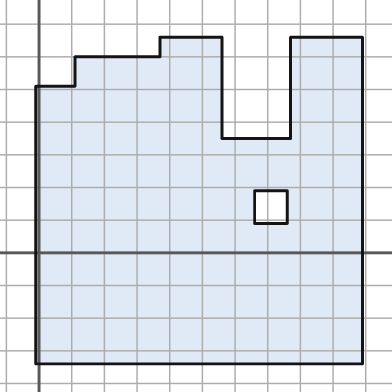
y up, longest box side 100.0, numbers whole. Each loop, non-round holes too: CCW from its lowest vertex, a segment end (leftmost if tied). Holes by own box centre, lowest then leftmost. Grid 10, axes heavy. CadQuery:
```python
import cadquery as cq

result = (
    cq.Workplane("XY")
    .moveTo(-1.0, -34.0)
    .lineTo(99.0, -34.0)
    .lineTo(99.0, 66.0)
    .lineTo(77.0, 66.0)
    .lineTo(77.0, 35.0)
    .lineTo(56.0, 35.0)
    .lineTo(56.0, 66.0)
    .lineTo(37.0, 66.0)
    .lineTo(37.0, 60.0)
    .lineTo(11.0, 60.0)
    .lineTo(11.0, 51.0)
    .lineTo(-1.0, 51.0)
    .close()
    .moveTo(66.0, 9.0)
    .lineTo(76.0, 9.0)
    .lineTo(76.0, 19.0)
    .lineTo(66.0, 19.0)
    .close()
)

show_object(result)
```